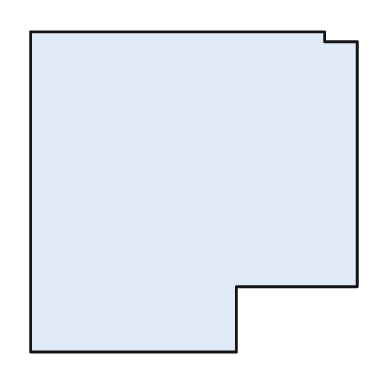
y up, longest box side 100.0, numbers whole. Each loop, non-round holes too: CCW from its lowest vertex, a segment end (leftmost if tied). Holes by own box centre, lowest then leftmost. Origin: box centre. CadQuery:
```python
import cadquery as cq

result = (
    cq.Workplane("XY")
    .moveTo(-50.0, -49.0)
    .lineTo(13.0, -49.0)
    .lineTo(13.0, -29.0)
    .lineTo(50.0, -29.0)
    .lineTo(50.0, 46.0)
    .lineTo(40.0, 46.0)
    .lineTo(40.0, 49.0)
    .lineTo(-50.0, 49.0)
    .close()
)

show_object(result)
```